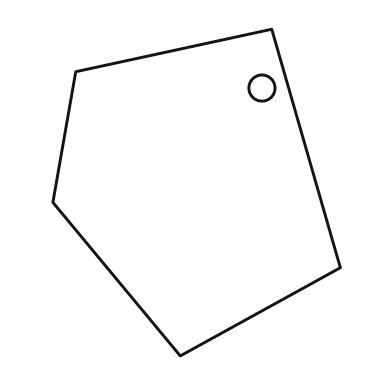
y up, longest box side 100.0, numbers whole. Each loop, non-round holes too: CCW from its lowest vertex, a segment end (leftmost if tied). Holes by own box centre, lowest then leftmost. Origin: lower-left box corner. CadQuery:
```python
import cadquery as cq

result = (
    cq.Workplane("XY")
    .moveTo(39.0, 0.0)
    .lineTo(88.0, 27.0)
    .lineTo(67.0, 100.0)
    .lineTo(7.0, 87.0)
    .lineTo(0.0, 47.0)
    .close()
    .moveTo(64.0, 82.0)
    .circle(4.0)
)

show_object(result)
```